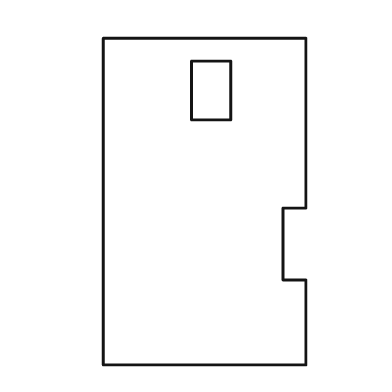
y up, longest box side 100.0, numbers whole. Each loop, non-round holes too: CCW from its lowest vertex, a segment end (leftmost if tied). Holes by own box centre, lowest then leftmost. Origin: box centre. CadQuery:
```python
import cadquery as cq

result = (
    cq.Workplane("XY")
    .moveTo(-31.0, -50.0)
    .lineTo(31.0, -50.0)
    .lineTo(31.0, -24.0)
    .lineTo(24.0, -24.0)
    .lineTo(24.0, -2.0)
    .lineTo(31.0, -2.0)
    .lineTo(31.0, 50.0)
    .lineTo(-31.0, 50.0)
    .close()
    .moveTo(-4.0, 25.0)
    .lineTo(8.0, 25.0)
    .lineTo(8.0, 43.0)
    .lineTo(-4.0, 43.0)
    .close()
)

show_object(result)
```